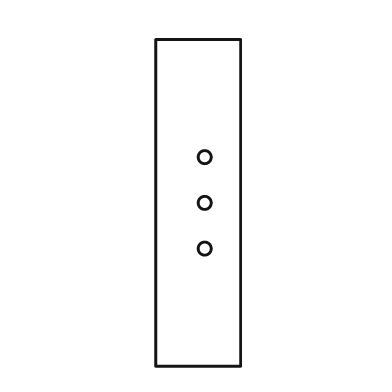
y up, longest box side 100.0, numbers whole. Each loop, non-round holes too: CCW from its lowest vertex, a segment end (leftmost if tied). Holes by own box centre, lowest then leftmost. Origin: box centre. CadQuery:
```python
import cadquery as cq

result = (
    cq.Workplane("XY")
    .moveTo(-13.0, -50.0)
    .lineTo(13.0, -50.0)
    .lineTo(13.0, 50.0)
    .lineTo(-13.0, 50.0)
    .close()
    .moveTo(2.0, -14.0)
    .circle(2.0)
    .moveTo(2.0, 0.0)
    .circle(2.0)
    .moveTo(2.0, 14.0)
    .circle(2.0)
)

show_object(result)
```